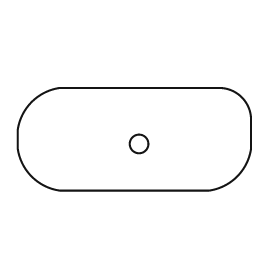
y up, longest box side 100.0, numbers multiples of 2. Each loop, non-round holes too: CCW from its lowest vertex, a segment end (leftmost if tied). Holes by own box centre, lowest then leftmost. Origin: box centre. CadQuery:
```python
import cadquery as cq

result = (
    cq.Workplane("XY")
    .moveTo(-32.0, -22.0)
    .lineTo(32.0, -22.0)
    .threePointArc((44.0, -16.0), (50.0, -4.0))
    .lineTo(50.0, 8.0)
    .threePointArc((46.0, 18.0), (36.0, 22.0))
    .lineTo(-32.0, 22.0)
    .threePointArc((-44.0, 16.0), (-50.0, 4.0))
    .lineTo(-50.0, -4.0)
    .threePointArc((-44.0, -16.0), (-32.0, -22.0))
    .close()
    .moveTo(2.0, -2.0)
    .circle(4.0)
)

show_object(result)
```